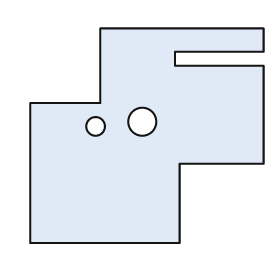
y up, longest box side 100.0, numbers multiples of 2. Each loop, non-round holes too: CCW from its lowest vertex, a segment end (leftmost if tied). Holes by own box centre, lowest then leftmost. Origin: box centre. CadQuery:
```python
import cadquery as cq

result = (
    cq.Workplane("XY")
    .moveTo(-50.0, -46.0)
    .lineTo(14.0, -46.0)
    .lineTo(14.0, -12.0)
    .lineTo(50.0, -12.0)
    .lineTo(50.0, 30.0)
    .lineTo(12.0, 30.0)
    .lineTo(12.0, 36.0)
    .lineTo(50.0, 36.0)
    .lineTo(50.0, 46.0)
    .lineTo(-20.0, 46.0)
    .lineTo(-20.0, 14.0)
    .lineTo(-50.0, 14.0)
    .close()
    .moveTo(-22.0, 4.0)
    .circle(4.0)
    .moveTo(-2.0, 6.0)
    .circle(6.0)
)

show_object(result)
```